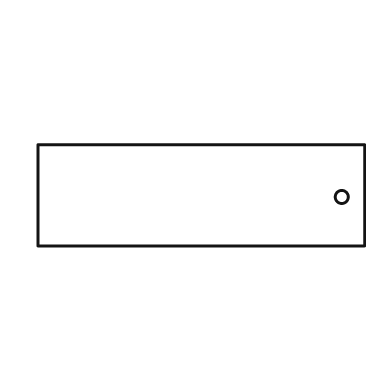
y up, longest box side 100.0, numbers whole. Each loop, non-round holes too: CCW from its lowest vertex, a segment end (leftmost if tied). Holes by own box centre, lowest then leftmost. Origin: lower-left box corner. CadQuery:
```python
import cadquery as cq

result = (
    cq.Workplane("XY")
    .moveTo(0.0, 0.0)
    .lineTo(100.0, 0.0)
    .lineTo(100.0, 31.0)
    .lineTo(0.0, 31.0)
    .close()
    .moveTo(93.0, 15.0)
    .circle(2.0)
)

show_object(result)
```